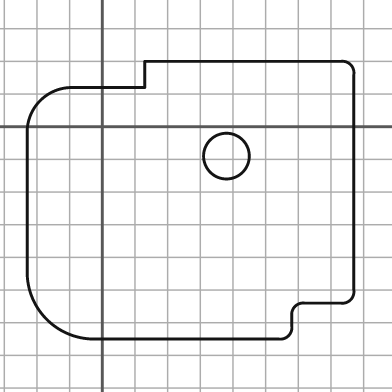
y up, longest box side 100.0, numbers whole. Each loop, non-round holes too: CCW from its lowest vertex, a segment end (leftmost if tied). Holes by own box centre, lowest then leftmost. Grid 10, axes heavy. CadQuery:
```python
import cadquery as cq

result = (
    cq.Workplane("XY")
    .moveTo(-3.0, -65.0)
    .lineTo(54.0, -65.0)
    .threePointArc((57.0, -64.0), (58.0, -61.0))
    .lineTo(58.0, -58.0)
    .threePointArc((59.0, -55.0), (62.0, -54.0))
    .lineTo(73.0, -54.0)
    .threePointArc((76.0, -53.0), (77.0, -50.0))
    .lineTo(77.0, 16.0)
    .threePointArc((76.0, 19.0), (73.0, 20.0))
    .lineTo(13.0, 20.0)
    .lineTo(13.0, 12.0)
    .lineTo(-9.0, 12.0)
    .threePointArc((-19.0, 8.0), (-23.0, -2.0))
    .lineTo(-23.0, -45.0)
    .threePointArc((-17.0, -59.0), (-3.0, -65.0))
    .close()
    .moveTo(38.0, -9.0)
    .circle(7.0)
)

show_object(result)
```